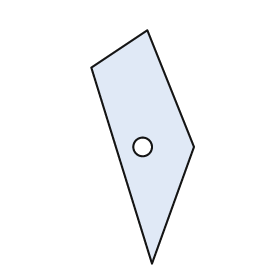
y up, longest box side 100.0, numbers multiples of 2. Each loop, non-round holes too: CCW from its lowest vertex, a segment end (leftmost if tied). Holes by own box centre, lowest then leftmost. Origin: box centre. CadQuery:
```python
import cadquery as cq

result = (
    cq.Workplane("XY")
    .moveTo(4.0, -50.0)
    .lineTo(22.0, 0.0)
    .lineTo(2.0, 50.0)
    .lineTo(-22.0, 34.0)
    .close()
    .moveTo(0.0, 0.0)
    .circle(4.0)
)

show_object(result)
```